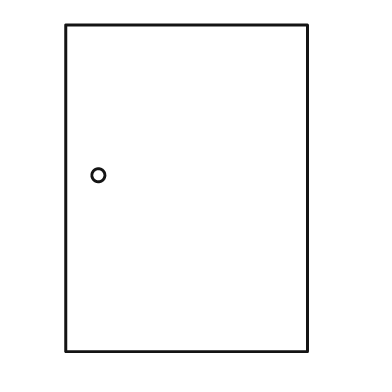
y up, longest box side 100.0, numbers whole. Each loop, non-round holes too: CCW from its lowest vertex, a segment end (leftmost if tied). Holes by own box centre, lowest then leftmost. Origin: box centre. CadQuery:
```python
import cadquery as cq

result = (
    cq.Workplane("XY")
    .moveTo(-37.0, -50.0)
    .lineTo(37.0, -50.0)
    .lineTo(37.0, 50.0)
    .lineTo(-37.0, 50.0)
    .close()
    .moveTo(-27.0, 4.0)
    .circle(2.0)
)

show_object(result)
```